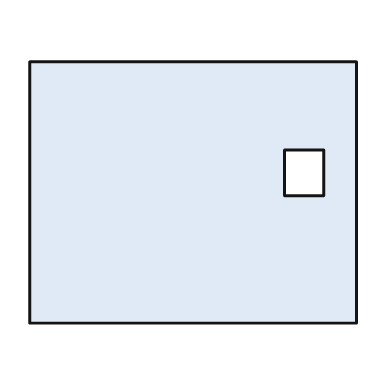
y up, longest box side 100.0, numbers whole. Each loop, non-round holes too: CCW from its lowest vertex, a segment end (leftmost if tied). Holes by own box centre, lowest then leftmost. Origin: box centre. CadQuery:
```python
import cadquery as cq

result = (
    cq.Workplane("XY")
    .moveTo(-50.0, -40.0)
    .lineTo(50.0, -40.0)
    .lineTo(50.0, 40.0)
    .lineTo(-50.0, 40.0)
    .close()
    .moveTo(28.0, -1.0)
    .lineTo(40.0, -1.0)
    .lineTo(40.0, 13.0)
    .lineTo(28.0, 13.0)
    .close()
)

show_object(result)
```